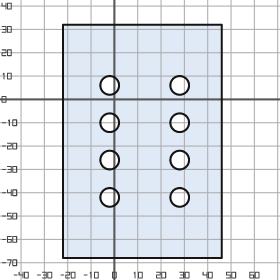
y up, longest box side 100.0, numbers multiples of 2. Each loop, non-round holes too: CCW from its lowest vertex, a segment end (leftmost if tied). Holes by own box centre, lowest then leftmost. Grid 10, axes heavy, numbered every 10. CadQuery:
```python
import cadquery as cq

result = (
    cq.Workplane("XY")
    .moveTo(-22.0, -68.0)
    .lineTo(46.0, -68.0)
    .lineTo(46.0, 32.0)
    .lineTo(-22.0, 32.0)
    .close()
    .moveTo(-2.0, -42.0)
    .circle(4.0)
    .moveTo(28.0, -42.0)
    .circle(4.0)
    .moveTo(-2.0, -26.0)
    .circle(4.0)
    .moveTo(28.0, -26.0)
    .circle(4.0)
    .moveTo(-2.0, -10.0)
    .circle(4.0)
    .moveTo(28.0, -10.0)
    .circle(4.0)
    .moveTo(-2.0, 6.0)
    .circle(4.0)
    .moveTo(28.0, 6.0)
    .circle(4.0)
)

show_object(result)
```